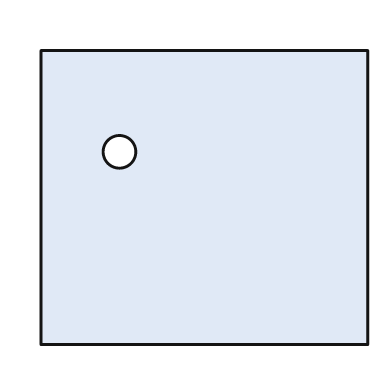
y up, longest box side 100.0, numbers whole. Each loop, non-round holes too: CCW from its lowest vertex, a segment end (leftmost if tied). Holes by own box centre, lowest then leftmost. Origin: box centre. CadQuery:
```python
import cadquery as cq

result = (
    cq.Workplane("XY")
    .moveTo(-50.0, -45.0)
    .lineTo(50.0, -45.0)
    .lineTo(50.0, 45.0)
    .lineTo(-50.0, 45.0)
    .close()
    .moveTo(-26.0, 14.0)
    .circle(5.0)
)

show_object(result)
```